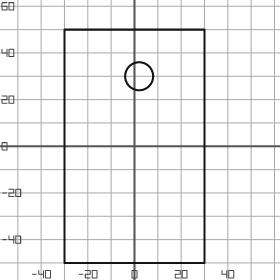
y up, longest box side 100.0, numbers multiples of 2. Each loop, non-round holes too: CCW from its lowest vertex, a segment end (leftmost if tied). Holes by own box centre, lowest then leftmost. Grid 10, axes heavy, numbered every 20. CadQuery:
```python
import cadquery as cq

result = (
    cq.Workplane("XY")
    .moveTo(-30.0, -50.0)
    .lineTo(30.0, -50.0)
    .lineTo(30.0, 50.0)
    .lineTo(-30.0, 50.0)
    .close()
    .moveTo(2.0, 30.0)
    .circle(6.0)
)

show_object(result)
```